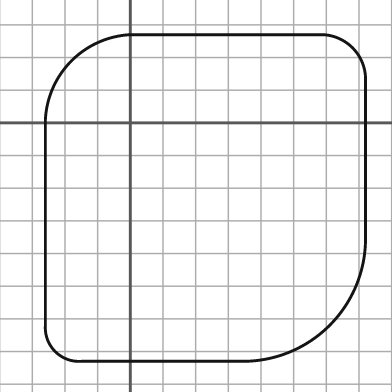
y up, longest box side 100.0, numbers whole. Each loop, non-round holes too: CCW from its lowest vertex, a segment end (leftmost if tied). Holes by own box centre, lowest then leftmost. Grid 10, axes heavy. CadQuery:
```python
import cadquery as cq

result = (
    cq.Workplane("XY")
    .moveTo(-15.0, -73.0)
    .lineTo(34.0, -73.0)
    .threePointArc((61.0, -62.0), (72.0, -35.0))
    .lineTo(72.0, 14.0)
    .threePointArc((68.0, 23.0), (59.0, 27.0))
    .lineTo(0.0, 27.0)
    .threePointArc((-18.0, 19.0), (-26.0, 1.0))
    .lineTo(-26.0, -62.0)
    .threePointArc((-23.0, -70.0), (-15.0, -73.0))
    .close()
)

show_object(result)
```